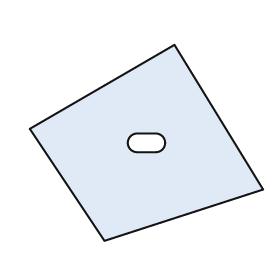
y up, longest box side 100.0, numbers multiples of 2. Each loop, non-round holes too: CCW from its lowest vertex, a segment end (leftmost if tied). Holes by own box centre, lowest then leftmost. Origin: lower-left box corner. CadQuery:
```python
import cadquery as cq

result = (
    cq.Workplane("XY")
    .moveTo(32.0, 0.0)
    .lineTo(100.0, 22.0)
    .lineTo(62.0, 84.0)
    .lineTo(0.0, 48.0)
    .close()
    .moveTo(46.0, 38.0)
    .lineTo(54.0, 38.0)
    .threePointArc((58.0, 42.0), (54.0, 46.0))
    .lineTo(46.0, 46.0)
    .threePointArc((42.0, 42.0), (46.0, 38.0))
    .close()
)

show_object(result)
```